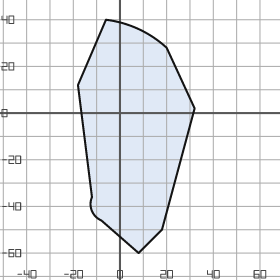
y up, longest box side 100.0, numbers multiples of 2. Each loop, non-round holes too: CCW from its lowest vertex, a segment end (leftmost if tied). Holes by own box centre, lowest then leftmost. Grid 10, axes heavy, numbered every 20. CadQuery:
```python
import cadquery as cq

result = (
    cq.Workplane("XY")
    .moveTo(8.0, -60.0)
    .lineTo(18.0, -50.0)
    .lineTo(32.0, 2.0)
    .lineTo(20.0, 28.0)
    .threePointArc((8.0, 36.0), (-6.0, 40.0))
    .lineTo(-18.0, 12.0)
    .lineTo(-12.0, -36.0)
    .threePointArc((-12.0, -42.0), (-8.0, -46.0))
    .close()
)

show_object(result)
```